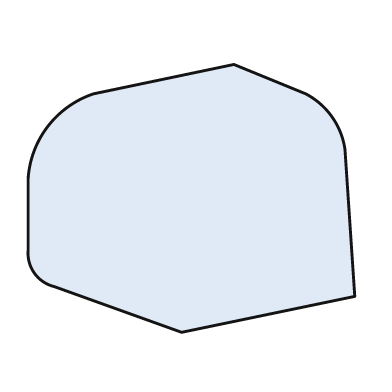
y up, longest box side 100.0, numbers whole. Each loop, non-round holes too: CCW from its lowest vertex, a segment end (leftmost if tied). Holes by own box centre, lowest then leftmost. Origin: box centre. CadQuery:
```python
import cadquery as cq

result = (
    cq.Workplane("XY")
    .moveTo(-3.0, -41.0)
    .lineTo(50.0, -30.0)
    .lineTo(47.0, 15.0)
    .threePointArc((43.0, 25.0), (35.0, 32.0))
    .lineTo(13.0, 41.0)
    .lineTo(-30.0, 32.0)
    .threePointArc((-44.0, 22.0), (-50.0, 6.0))
    .lineTo(-50.0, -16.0)
    .threePointArc((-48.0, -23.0), (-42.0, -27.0))
    .close()
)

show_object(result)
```